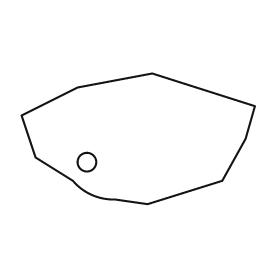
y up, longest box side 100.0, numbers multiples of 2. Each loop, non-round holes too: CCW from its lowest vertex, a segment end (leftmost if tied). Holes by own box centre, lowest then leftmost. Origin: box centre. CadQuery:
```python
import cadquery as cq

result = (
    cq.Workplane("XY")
    .moveTo(4.0, -28.0)
    .lineTo(36.0, -18.0)
    .lineTo(46.0, 0.0)
    .lineTo(50.0, 14.0)
    .lineTo(6.0, 28.0)
    .lineTo(-26.0, 22.0)
    .lineTo(-50.0, 10.0)
    .lineTo(-44.0, -8.0)
    .lineTo(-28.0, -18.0)
    .threePointArc((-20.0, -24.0), (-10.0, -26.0))
    .close()
    .moveTo(-22.0, -10.0)
    .circle(4.0)
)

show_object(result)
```